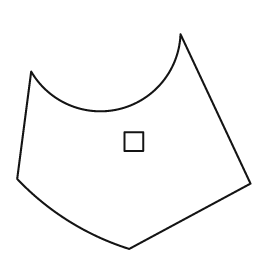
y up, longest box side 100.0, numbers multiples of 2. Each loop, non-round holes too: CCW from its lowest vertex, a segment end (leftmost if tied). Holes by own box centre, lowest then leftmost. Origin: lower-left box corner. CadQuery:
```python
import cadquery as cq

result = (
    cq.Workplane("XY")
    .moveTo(48.0, 0.0)
    .lineTo(100.0, 28.0)
    .lineTo(70.0, 92.0)
    .threePointArc((44.0, 60.0), (6.0, 76.0))
    .lineTo(0.0, 30.0)
    .threePointArc((22.0, 12.0), (48.0, 0.0))
    .close()
    .moveTo(46.0, 42.0)
    .lineTo(54.0, 42.0)
    .lineTo(54.0, 50.0)
    .lineTo(46.0, 50.0)
    .close()
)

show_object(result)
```